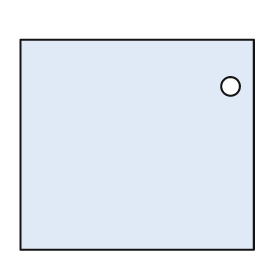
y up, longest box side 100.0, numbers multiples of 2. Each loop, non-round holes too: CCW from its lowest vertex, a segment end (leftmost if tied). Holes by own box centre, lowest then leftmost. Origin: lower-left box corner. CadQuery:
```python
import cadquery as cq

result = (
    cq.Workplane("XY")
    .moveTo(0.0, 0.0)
    .lineTo(100.0, 0.0)
    .lineTo(100.0, 90.0)
    .lineTo(0.0, 90.0)
    .close()
    .moveTo(90.0, 70.0)
    .circle(4.0)
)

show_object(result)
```